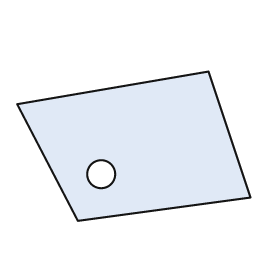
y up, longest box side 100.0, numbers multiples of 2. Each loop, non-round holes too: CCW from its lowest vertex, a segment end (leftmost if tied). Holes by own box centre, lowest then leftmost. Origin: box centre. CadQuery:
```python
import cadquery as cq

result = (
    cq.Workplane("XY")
    .moveTo(-24.0, -32.0)
    .lineTo(50.0, -22.0)
    .lineTo(32.0, 32.0)
    .lineTo(-50.0, 18.0)
    .close()
    .moveTo(-14.0, -12.0)
    .circle(6.0)
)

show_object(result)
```